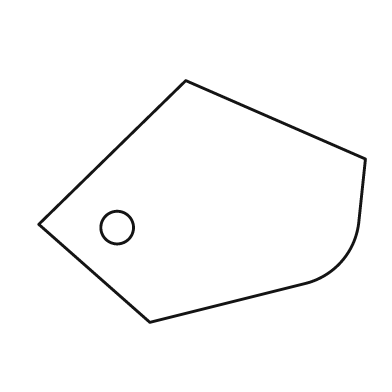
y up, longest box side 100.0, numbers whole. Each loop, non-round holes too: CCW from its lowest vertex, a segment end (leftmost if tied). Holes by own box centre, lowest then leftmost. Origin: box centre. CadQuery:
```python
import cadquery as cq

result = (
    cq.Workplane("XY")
    .moveTo(-16.0, -37.0)
    .lineTo(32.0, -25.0)
    .threePointArc((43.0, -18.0), (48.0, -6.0))
    .lineTo(50.0, 13.0)
    .lineTo(-5.0, 37.0)
    .lineTo(-50.0, -7.0)
    .close()
    .moveTo(-26.0, -8.0)
    .circle(5.0)
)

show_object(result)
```